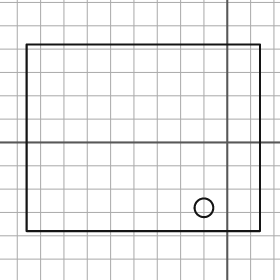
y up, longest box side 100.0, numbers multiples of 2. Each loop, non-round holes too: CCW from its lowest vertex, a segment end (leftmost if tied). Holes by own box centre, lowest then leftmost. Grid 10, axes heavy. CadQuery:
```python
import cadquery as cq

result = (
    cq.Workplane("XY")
    .moveTo(-86.0, -38.0)
    .lineTo(14.0, -38.0)
    .lineTo(14.0, 42.0)
    .lineTo(-86.0, 42.0)
    .close()
    .moveTo(-10.0, -28.0)
    .circle(4.0)
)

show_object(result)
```